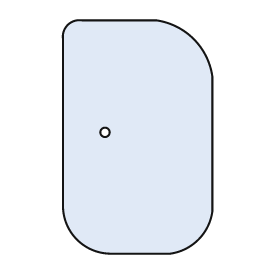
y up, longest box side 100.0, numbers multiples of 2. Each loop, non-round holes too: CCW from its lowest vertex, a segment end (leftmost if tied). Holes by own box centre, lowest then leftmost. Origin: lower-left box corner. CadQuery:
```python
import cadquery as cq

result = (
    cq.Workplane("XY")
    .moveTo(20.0, 0.0)
    .lineTo(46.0, 0.0)
    .threePointArc((58.0, 6.0), (64.0, 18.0))
    .lineTo(64.0, 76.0)
    .threePointArc((56.0, 92.0), (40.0, 100.0))
    .lineTo(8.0, 100.0)
    .threePointArc((2.0, 98.0), (0.0, 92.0))
    .lineTo(0.0, 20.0)
    .threePointArc((6.0, 6.0), (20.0, 0.0))
    .close()
    .moveTo(18.0, 52.0)
    .circle(2.0)
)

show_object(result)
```